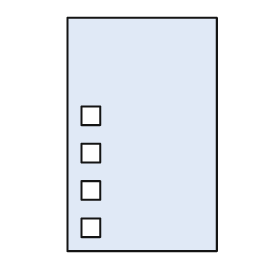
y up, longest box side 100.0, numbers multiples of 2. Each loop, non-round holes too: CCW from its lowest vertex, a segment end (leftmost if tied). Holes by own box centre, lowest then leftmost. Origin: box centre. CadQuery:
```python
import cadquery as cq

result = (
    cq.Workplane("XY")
    .moveTo(-32.0, -50.0)
    .lineTo(32.0, -50.0)
    .lineTo(32.0, 50.0)
    .lineTo(-32.0, 50.0)
    .close()
    .moveTo(-26.0, -44.0)
    .lineTo(-18.0, -44.0)
    .lineTo(-18.0, -36.0)
    .lineTo(-26.0, -36.0)
    .close()
    .moveTo(-26.0, -28.0)
    .lineTo(-18.0, -28.0)
    .lineTo(-18.0, -20.0)
    .lineTo(-26.0, -20.0)
    .close()
    .moveTo(-26.0, -12.0)
    .lineTo(-18.0, -12.0)
    .lineTo(-18.0, -4.0)
    .lineTo(-26.0, -4.0)
    .close()
    .moveTo(-26.0, 4.0)
    .lineTo(-18.0, 4.0)
    .lineTo(-18.0, 12.0)
    .lineTo(-26.0, 12.0)
    .close()
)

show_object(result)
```